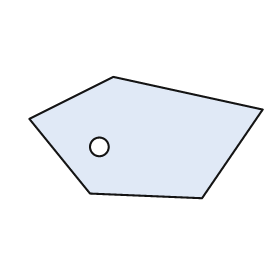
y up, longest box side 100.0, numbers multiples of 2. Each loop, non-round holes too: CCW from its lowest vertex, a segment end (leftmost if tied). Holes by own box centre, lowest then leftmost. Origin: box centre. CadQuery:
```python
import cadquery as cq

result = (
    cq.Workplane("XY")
    .moveTo(24.0, -26.0)
    .lineTo(50.0, 12.0)
    .lineTo(-14.0, 26.0)
    .lineTo(-50.0, 8.0)
    .lineTo(-24.0, -24.0)
    .close()
    .moveTo(-20.0, -4.0)
    .circle(4.0)
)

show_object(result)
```